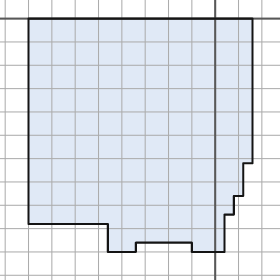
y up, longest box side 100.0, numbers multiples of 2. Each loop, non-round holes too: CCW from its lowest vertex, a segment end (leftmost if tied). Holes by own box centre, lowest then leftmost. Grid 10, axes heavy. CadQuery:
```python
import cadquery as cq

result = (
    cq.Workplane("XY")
    .moveTo(-46.0, -100.0)
    .lineTo(-34.0, -100.0)
    .lineTo(-34.0, -96.0)
    .lineTo(-10.0, -96.0)
    .lineTo(-10.0, -100.0)
    .lineTo(4.0, -100.0)
    .lineTo(4.0, -84.0)
    .lineTo(8.0, -84.0)
    .lineTo(8.0, -76.0)
    .lineTo(12.0, -76.0)
    .lineTo(12.0, -62.0)
    .lineTo(16.0, -62.0)
    .lineTo(16.0, 0.0)
    .lineTo(-80.0, 0.0)
    .lineTo(-80.0, -88.0)
    .lineTo(-46.0, -88.0)
    .close()
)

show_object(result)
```